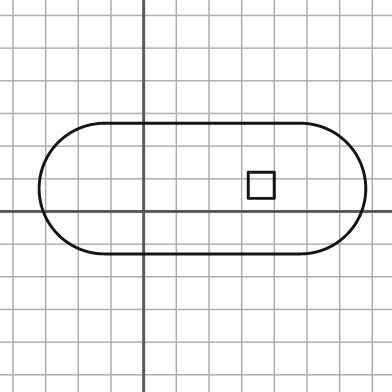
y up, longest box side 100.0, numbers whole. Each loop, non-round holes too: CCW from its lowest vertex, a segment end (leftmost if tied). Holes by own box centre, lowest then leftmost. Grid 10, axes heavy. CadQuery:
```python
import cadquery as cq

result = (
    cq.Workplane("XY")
    .moveTo(-12.0, -13.0)
    .lineTo(48.0, -13.0)
    .threePointArc((68.0, 7.0), (48.0, 27.0))
    .lineTo(-12.0, 27.0)
    .threePointArc((-32.0, 7.0), (-12.0, -13.0))
    .close()
    .moveTo(32.0, 4.0)
    .lineTo(40.0, 4.0)
    .lineTo(40.0, 12.0)
    .lineTo(32.0, 12.0)
    .close()
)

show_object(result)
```